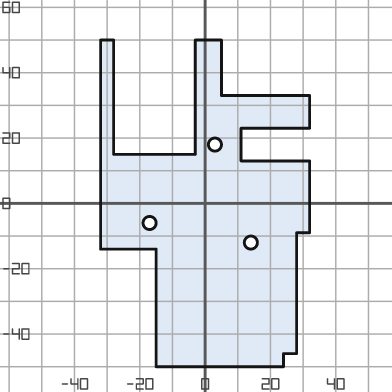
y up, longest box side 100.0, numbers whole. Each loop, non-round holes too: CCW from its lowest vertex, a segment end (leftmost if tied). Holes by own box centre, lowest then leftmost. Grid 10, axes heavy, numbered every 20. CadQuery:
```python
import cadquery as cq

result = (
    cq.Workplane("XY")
    .moveTo(-15.0, -50.0)
    .lineTo(24.0, -50.0)
    .lineTo(24.0, -46.0)
    .lineTo(28.0, -46.0)
    .lineTo(28.0, -9.0)
    .lineTo(32.0, -9.0)
    .lineTo(32.0, 13.0)
    .lineTo(11.0, 13.0)
    .lineTo(11.0, 23.0)
    .lineTo(32.0, 23.0)
    .lineTo(32.0, 33.0)
    .lineTo(5.0, 33.0)
    .lineTo(5.0, 50.0)
    .lineTo(-3.0, 50.0)
    .lineTo(-3.0, 15.0)
    .lineTo(-28.0, 15.0)
    .lineTo(-28.0, 50.0)
    .lineTo(-32.0, 50.0)
    .lineTo(-32.0, -14.0)
    .lineTo(-15.0, -14.0)
    .close()
    .moveTo(14.0, -12.0)
    .circle(2.0)
    .moveTo(-17.0, -6.0)
    .circle(2.0)
    .moveTo(3.0, 18.0)
    .circle(2.0)
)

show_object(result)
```